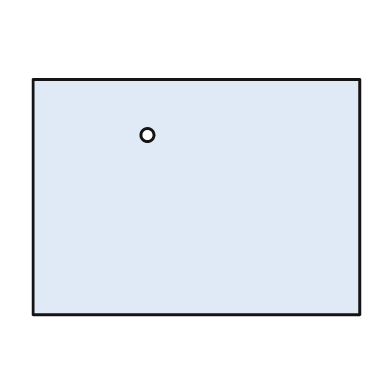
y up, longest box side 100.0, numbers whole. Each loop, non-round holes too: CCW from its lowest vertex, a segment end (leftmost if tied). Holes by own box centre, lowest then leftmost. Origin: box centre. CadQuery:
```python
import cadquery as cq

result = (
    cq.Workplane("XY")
    .moveTo(-50.0, -36.0)
    .lineTo(50.0, -36.0)
    .lineTo(50.0, 36.0)
    .lineTo(-50.0, 36.0)
    .close()
    .moveTo(-15.0, 19.0)
    .circle(2.0)
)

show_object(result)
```